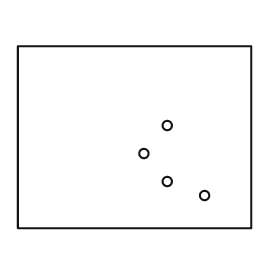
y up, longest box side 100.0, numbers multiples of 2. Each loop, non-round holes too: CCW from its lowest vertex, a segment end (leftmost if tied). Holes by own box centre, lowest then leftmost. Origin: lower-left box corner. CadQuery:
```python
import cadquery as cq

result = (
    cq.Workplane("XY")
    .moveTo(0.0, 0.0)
    .lineTo(100.0, 0.0)
    .lineTo(100.0, 78.0)
    .lineTo(0.0, 78.0)
    .close()
    .moveTo(80.0, 14.0)
    .circle(2.0)
    .moveTo(64.0, 20.0)
    .circle(2.0)
    .moveTo(54.0, 32.0)
    .circle(2.0)
    .moveTo(64.0, 44.0)
    .circle(2.0)
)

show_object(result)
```